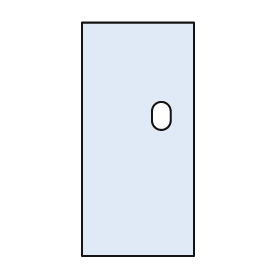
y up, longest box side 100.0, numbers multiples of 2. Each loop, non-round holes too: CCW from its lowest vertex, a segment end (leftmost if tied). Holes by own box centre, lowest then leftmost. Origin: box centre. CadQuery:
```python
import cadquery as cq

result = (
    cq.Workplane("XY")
    .moveTo(-24.0, -50.0)
    .lineTo(24.0, -50.0)
    .lineTo(24.0, 50.0)
    .lineTo(-24.0, 50.0)
    .close()
    .moveTo(6.0, 8.0)
    .threePointArc((10.0, 4.0), (14.0, 8.0))
    .lineTo(14.0, 12.0)
    .threePointArc((10.0, 16.0), (6.0, 12.0))
    .close()
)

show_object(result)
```